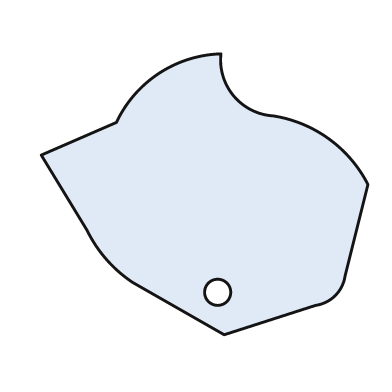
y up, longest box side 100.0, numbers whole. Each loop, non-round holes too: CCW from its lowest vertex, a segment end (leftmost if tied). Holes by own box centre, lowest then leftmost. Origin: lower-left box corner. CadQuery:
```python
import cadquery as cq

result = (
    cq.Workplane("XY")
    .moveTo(56.0, 0.0)
    .lineTo(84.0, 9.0)
    .threePointArc((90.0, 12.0), (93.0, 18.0))
    .lineTo(100.0, 46.0)
    .threePointArc((88.0, 60.0), (71.0, 67.0))
    .threePointArc((59.0, 73.0), (55.0, 86.0))
    .threePointArc((36.0, 80.0), (23.0, 65.0))
    .lineTo(0.0, 55.0)
    .lineTo(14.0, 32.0)
    .threePointArc((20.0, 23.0), (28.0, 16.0))
    .close()
    .moveTo(54.0, 13.0)
    .circle(4.0)
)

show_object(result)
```